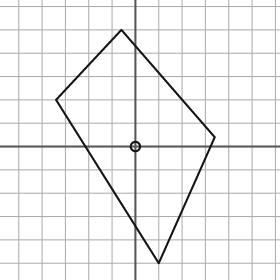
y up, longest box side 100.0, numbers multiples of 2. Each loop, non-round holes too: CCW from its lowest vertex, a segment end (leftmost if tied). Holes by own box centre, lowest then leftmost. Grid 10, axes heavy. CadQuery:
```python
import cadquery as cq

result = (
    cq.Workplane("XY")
    .moveTo(10.0, -50.0)
    .lineTo(34.0, 4.0)
    .lineTo(-6.0, 50.0)
    .lineTo(-34.0, 20.0)
    .close()
    .moveTo(0.0, 0.0)
    .circle(2.0)
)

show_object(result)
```